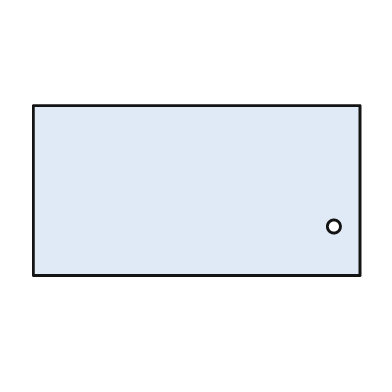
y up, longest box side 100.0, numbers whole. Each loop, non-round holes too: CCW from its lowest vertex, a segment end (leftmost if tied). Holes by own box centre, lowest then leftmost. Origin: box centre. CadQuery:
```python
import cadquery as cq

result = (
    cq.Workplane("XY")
    .moveTo(-50.0, -26.0)
    .lineTo(50.0, -26.0)
    .lineTo(50.0, 26.0)
    .lineTo(-50.0, 26.0)
    .close()
    .moveTo(42.0, -11.0)
    .circle(2.0)
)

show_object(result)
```